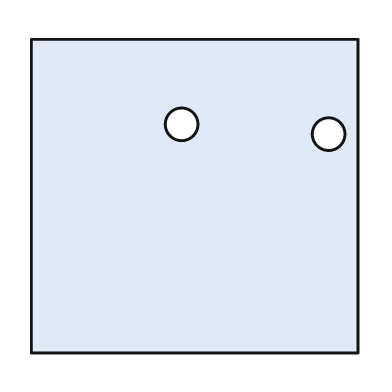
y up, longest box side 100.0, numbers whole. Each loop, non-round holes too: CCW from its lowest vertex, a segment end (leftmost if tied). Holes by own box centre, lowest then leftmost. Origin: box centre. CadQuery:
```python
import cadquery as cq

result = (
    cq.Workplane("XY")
    .moveTo(-50.0, -48.0)
    .lineTo(50.0, -48.0)
    .lineTo(50.0, 48.0)
    .lineTo(-50.0, 48.0)
    .close()
    .moveTo(41.0, 19.0)
    .circle(5.0)
    .moveTo(-4.0, 22.0)
    .circle(5.0)
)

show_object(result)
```